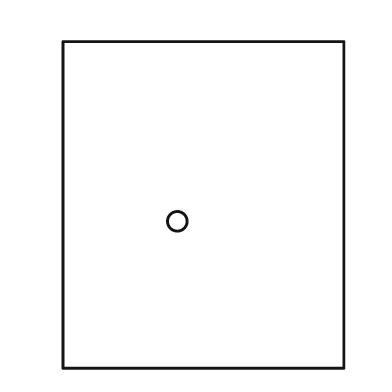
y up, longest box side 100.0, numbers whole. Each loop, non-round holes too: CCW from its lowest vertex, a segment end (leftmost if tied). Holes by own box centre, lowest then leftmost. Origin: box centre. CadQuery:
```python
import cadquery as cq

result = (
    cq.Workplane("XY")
    .moveTo(-43.0, -50.0)
    .lineTo(43.0, -50.0)
    .lineTo(43.0, 50.0)
    .lineTo(-43.0, 50.0)
    .close()
    .moveTo(-8.0, -5.0)
    .circle(3.0)
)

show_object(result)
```